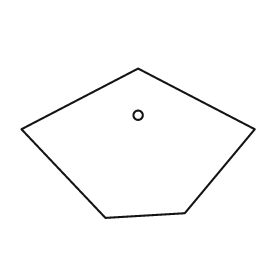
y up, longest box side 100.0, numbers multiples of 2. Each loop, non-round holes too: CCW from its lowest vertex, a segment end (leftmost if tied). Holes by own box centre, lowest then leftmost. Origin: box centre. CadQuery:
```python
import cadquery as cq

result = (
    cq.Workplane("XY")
    .moveTo(-14.0, -32.0)
    .lineTo(20.0, -30.0)
    .lineTo(50.0, 6.0)
    .lineTo(0.0, 32.0)
    .lineTo(-50.0, 6.0)
    .close()
    .moveTo(0.0, 12.0)
    .circle(2.0)
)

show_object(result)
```